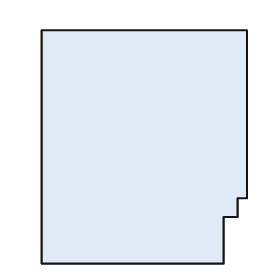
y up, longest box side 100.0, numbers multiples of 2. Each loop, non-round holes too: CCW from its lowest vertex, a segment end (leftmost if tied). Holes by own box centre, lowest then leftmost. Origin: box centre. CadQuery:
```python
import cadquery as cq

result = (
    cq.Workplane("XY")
    .moveTo(-44.0, -50.0)
    .lineTo(34.0, -50.0)
    .lineTo(34.0, -30.0)
    .lineTo(40.0, -30.0)
    .lineTo(40.0, -22.0)
    .lineTo(44.0, -22.0)
    .lineTo(44.0, 50.0)
    .lineTo(-44.0, 50.0)
    .close()
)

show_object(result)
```